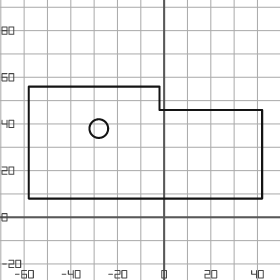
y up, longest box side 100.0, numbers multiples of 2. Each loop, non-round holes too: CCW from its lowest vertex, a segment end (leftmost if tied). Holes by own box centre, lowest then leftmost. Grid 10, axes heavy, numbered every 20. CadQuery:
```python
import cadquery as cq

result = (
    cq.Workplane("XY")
    .moveTo(-58.0, 8.0)
    .lineTo(42.0, 8.0)
    .lineTo(42.0, 46.0)
    .lineTo(-2.0, 46.0)
    .lineTo(-2.0, 56.0)
    .lineTo(-58.0, 56.0)
    .close()
    .moveTo(-28.0, 38.0)
    .circle(4.0)
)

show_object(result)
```